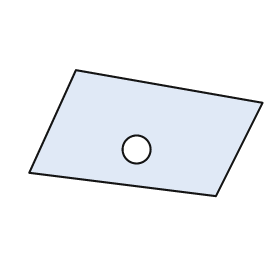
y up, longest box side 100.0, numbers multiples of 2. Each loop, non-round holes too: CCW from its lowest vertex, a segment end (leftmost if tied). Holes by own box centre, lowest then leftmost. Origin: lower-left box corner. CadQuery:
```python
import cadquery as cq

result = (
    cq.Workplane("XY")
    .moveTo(80.0, 0.0)
    .lineTo(100.0, 40.0)
    .lineTo(20.0, 54.0)
    .lineTo(0.0, 10.0)
    .close()
    .moveTo(46.0, 20.0)
    .circle(6.0)
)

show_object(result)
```